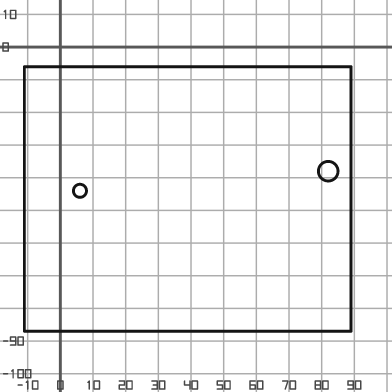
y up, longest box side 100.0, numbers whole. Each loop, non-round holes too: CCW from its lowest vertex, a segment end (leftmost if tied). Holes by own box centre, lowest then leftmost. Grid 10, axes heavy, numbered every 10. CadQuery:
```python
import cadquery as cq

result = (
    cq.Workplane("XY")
    .moveTo(-11.0, -87.0)
    .lineTo(89.0, -87.0)
    .lineTo(89.0, -6.0)
    .lineTo(-11.0, -6.0)
    .close()
    .moveTo(6.0, -44.0)
    .circle(2.0)
    .moveTo(82.0, -38.0)
    .circle(3.0)
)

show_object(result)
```